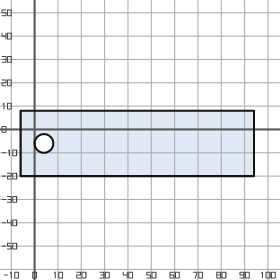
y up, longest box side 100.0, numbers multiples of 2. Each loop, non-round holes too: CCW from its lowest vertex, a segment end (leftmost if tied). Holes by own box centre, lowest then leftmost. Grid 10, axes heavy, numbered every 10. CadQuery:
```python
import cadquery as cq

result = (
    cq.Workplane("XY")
    .moveTo(-6.0, -20.0)
    .lineTo(94.0, -20.0)
    .lineTo(94.0, 8.0)
    .lineTo(-6.0, 8.0)
    .close()
    .moveTo(4.0, -6.0)
    .circle(4.0)
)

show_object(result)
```